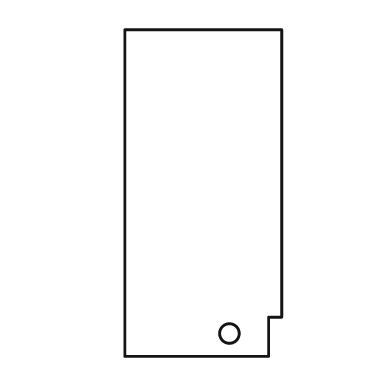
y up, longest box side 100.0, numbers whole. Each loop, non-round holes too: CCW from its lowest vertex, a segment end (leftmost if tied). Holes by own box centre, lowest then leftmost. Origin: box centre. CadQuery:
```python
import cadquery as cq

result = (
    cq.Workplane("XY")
    .moveTo(-24.0, -50.0)
    .lineTo(20.0, -50.0)
    .lineTo(20.0, -38.0)
    .lineTo(24.0, -38.0)
    .lineTo(24.0, 50.0)
    .lineTo(-24.0, 50.0)
    .close()
    .moveTo(8.0, -43.0)
    .circle(3.0)
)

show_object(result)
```